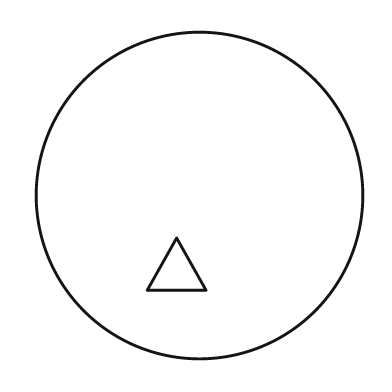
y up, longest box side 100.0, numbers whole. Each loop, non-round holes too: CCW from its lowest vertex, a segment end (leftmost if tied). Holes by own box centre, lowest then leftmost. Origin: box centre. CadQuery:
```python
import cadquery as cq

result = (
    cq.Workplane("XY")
    .moveTo(0.0, 0.0)
    .circle(50.0)
    .moveTo(-16.0, -29.0)
    .lineTo(2.0, -29.0)
    .lineTo(-7.0, -13.0)
    .close()
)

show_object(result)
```